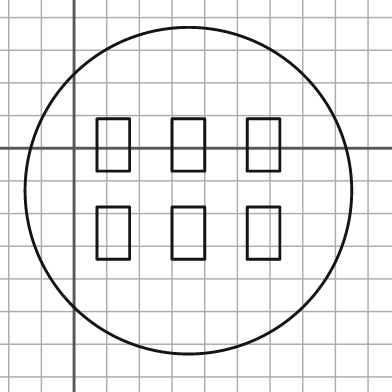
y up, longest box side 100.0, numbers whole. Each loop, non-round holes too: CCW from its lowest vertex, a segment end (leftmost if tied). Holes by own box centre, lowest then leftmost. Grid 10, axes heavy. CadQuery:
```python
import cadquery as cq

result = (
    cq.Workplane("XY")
    .moveTo(35.0, -13.0)
    .circle(50.0)
    .moveTo(7.0, -34.0)
    .lineTo(17.0, -34.0)
    .lineTo(17.0, -18.0)
    .lineTo(7.0, -18.0)
    .close()
    .moveTo(30.0, -34.0)
    .lineTo(40.0, -34.0)
    .lineTo(40.0, -18.0)
    .lineTo(30.0, -18.0)
    .close()
    .moveTo(53.0, -34.0)
    .lineTo(63.0, -34.0)
    .lineTo(63.0, -18.0)
    .lineTo(53.0, -18.0)
    .close()
    .moveTo(7.0, -7.0)
    .lineTo(17.0, -7.0)
    .lineTo(17.0, 9.0)
    .lineTo(7.0, 9.0)
    .close()
    .moveTo(30.0, -7.0)
    .lineTo(40.0, -7.0)
    .lineTo(40.0, 9.0)
    .lineTo(30.0, 9.0)
    .close()
    .moveTo(53.0, -7.0)
    .lineTo(63.0, -7.0)
    .lineTo(63.0, 9.0)
    .lineTo(53.0, 9.0)
    .close()
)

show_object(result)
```